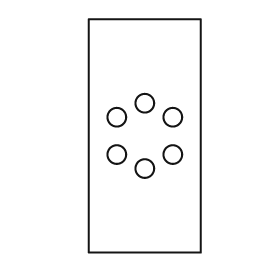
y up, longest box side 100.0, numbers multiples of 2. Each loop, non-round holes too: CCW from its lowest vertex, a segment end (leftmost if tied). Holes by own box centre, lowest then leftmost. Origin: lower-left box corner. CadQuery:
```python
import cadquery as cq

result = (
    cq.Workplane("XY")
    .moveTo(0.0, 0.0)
    .lineTo(48.0, 0.0)
    .lineTo(48.0, 100.0)
    .lineTo(0.0, 100.0)
    .close()
    .moveTo(24.0, 36.0)
    .circle(4.0)
    .moveTo(12.0, 42.0)
    .circle(4.0)
    .moveTo(36.0, 42.0)
    .circle(4.0)
    .moveTo(12.0, 58.0)
    .circle(4.0)
    .moveTo(36.0, 58.0)
    .circle(4.0)
    .moveTo(24.0, 64.0)
    .circle(4.0)
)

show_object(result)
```